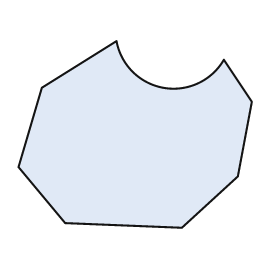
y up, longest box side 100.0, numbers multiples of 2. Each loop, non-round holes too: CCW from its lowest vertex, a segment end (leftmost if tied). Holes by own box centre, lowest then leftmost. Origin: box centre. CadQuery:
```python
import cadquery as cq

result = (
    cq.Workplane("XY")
    .moveTo(20.0, -40.0)
    .lineTo(44.0, -18.0)
    .lineTo(50.0, 14.0)
    .lineTo(38.0, 32.0)
    .threePointArc((12.0, 20.0), (-8.0, 40.0))
    .lineTo(-40.0, 20.0)
    .lineTo(-50.0, -14.0)
    .lineTo(-30.0, -38.0)
    .close()
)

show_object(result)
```